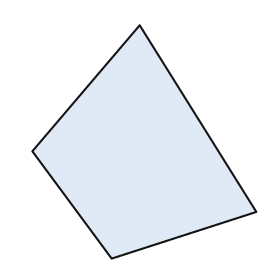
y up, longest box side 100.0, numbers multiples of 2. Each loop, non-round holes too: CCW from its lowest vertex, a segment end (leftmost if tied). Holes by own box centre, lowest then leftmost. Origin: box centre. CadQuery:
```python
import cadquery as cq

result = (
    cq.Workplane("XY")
    .moveTo(-14.0, -50.0)
    .lineTo(48.0, -30.0)
    .lineTo(-2.0, 50.0)
    .lineTo(-48.0, -4.0)
    .close()
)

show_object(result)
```